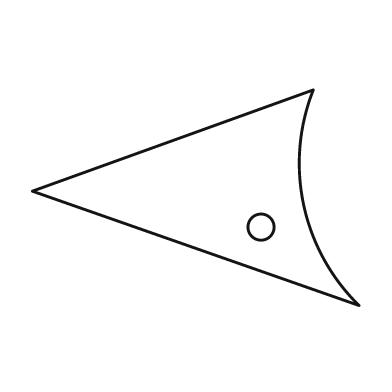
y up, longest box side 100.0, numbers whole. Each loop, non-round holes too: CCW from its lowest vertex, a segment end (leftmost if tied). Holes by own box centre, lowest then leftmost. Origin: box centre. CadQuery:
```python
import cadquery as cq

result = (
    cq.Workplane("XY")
    .moveTo(50.0, -33.0)
    .threePointArc((33.0, -2.0), (36.0, 33.0))
    .lineTo(-50.0, 2.0)
    .close()
    .moveTo(20.0, -9.0)
    .circle(4.0)
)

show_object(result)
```